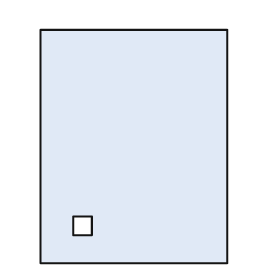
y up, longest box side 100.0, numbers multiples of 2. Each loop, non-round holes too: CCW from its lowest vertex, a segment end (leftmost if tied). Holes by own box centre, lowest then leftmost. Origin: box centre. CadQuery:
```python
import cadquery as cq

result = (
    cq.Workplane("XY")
    .moveTo(-40.0, -50.0)
    .lineTo(40.0, -50.0)
    .lineTo(40.0, 50.0)
    .lineTo(-40.0, 50.0)
    .close()
    .moveTo(-26.0, -38.0)
    .lineTo(-18.0, -38.0)
    .lineTo(-18.0, -30.0)
    .lineTo(-26.0, -30.0)
    .close()
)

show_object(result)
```